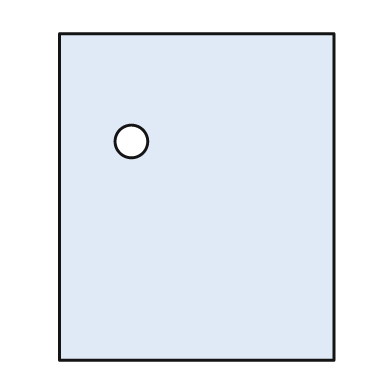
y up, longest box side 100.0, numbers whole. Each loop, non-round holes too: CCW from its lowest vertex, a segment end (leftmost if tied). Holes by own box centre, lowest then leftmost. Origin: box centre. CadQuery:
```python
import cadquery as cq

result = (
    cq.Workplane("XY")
    .moveTo(-42.0, -50.0)
    .lineTo(42.0, -50.0)
    .lineTo(42.0, 50.0)
    .lineTo(-42.0, 50.0)
    .close()
    .moveTo(-20.0, 17.0)
    .circle(5.0)
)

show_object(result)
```